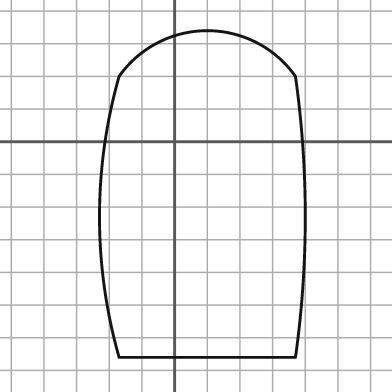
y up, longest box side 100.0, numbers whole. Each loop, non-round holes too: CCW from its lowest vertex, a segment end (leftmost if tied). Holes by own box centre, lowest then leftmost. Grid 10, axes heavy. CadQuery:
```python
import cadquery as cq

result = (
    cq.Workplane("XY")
    .moveTo(-17.0, -66.0)
    .lineTo(37.0, -66.0)
    .threePointArc((40.0, -23.0), (37.0, 20.0))
    .threePointArc((10.0, 34.0), (-17.0, 20.0))
    .threePointArc((-23.0, -23.0), (-17.0, -66.0))
    .close()
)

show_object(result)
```